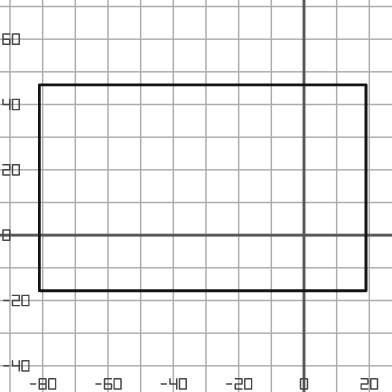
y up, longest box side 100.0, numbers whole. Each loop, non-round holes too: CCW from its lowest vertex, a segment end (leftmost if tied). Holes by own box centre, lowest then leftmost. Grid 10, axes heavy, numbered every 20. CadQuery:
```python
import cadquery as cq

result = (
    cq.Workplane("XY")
    .moveTo(-81.0, -17.0)
    .lineTo(19.0, -17.0)
    .lineTo(19.0, 46.0)
    .lineTo(-81.0, 46.0)
    .close()
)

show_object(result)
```